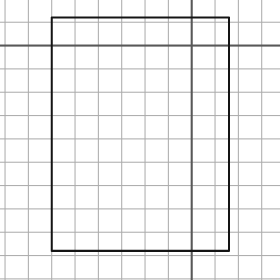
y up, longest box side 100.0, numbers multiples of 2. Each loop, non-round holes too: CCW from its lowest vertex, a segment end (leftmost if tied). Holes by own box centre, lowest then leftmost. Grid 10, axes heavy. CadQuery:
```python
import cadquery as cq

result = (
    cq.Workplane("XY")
    .moveTo(-60.0, -88.0)
    .lineTo(16.0, -88.0)
    .lineTo(16.0, 12.0)
    .lineTo(-60.0, 12.0)
    .close()
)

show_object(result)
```